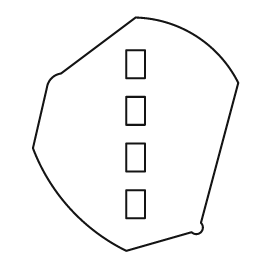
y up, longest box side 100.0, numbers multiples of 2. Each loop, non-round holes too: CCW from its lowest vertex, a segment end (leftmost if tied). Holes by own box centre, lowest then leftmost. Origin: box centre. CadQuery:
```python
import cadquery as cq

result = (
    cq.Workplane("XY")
    .moveTo(-4.0, -50.0)
    .lineTo(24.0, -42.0)
    .threePointArc((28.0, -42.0), (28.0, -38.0))
    .lineTo(44.0, 22.0)
    .threePointArc((26.0, 42.0), (0.0, 50.0))
    .lineTo(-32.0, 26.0)
    .threePointArc((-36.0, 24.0), (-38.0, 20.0))
    .lineTo(-44.0, -6.0)
    .threePointArc((-28.0, -32.0), (-4.0, -50.0))
    .close()
    .moveTo(-4.0, -36.0)
    .lineTo(4.0, -36.0)
    .lineTo(4.0, -24.0)
    .lineTo(-4.0, -24.0)
    .close()
    .moveTo(-4.0, -16.0)
    .lineTo(4.0, -16.0)
    .lineTo(4.0, -4.0)
    .lineTo(-4.0, -4.0)
    .close()
    .moveTo(-4.0, 4.0)
    .lineTo(4.0, 4.0)
    .lineTo(4.0, 16.0)
    .lineTo(-4.0, 16.0)
    .close()
    .moveTo(-4.0, 24.0)
    .lineTo(4.0, 24.0)
    .lineTo(4.0, 36.0)
    .lineTo(-4.0, 36.0)
    .close()
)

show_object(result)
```